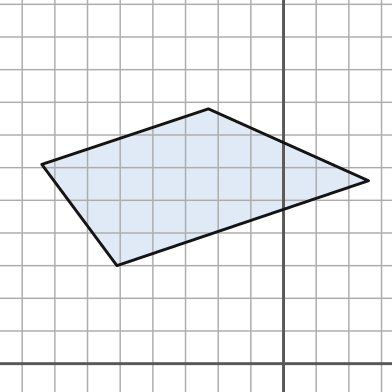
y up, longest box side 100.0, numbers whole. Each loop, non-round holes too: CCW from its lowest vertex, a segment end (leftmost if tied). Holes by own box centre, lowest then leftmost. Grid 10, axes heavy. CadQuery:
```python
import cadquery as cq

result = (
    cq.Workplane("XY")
    .moveTo(-51.0, 30.0)
    .lineTo(26.0, 56.0)
    .lineTo(-23.0, 78.0)
    .lineTo(-74.0, 61.0)
    .close()
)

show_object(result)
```